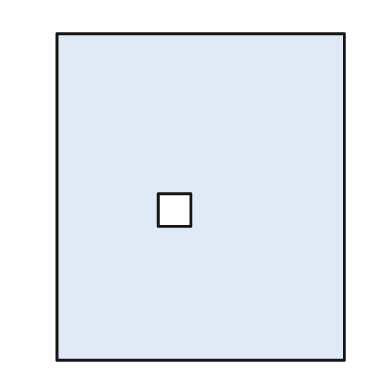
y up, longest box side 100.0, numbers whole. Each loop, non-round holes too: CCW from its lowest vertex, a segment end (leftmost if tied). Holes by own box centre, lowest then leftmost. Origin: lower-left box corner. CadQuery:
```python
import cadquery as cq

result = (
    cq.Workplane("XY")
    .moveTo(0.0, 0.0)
    .lineTo(88.0, 0.0)
    .lineTo(88.0, 100.0)
    .lineTo(0.0, 100.0)
    .close()
    .moveTo(31.0, 41.0)
    .lineTo(41.0, 41.0)
    .lineTo(41.0, 51.0)
    .lineTo(31.0, 51.0)
    .close()
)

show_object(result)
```